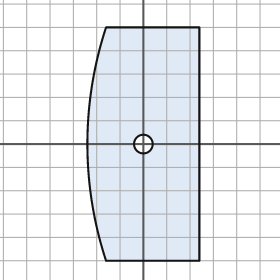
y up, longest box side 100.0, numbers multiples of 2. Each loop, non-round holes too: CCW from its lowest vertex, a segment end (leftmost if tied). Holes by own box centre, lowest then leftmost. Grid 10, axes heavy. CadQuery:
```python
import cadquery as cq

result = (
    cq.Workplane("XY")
    .moveTo(-16.0, -50.0)
    .lineTo(24.0, -50.0)
    .lineTo(24.0, 50.0)
    .lineTo(-16.0, 50.0)
    .threePointArc((-24.0, 0.0), (-16.0, -50.0))
    .close()
    .moveTo(0.0, 0.0)
    .circle(4.0)
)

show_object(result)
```